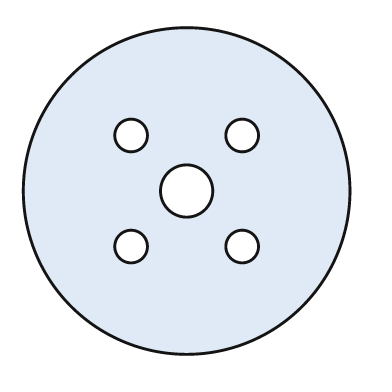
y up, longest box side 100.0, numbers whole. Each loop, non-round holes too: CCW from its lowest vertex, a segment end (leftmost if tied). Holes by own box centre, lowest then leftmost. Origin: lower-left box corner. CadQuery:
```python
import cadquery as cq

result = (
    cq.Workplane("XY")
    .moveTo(50.0, 50.0)
    .circle(50.0)
    .moveTo(33.0, 33.0)
    .circle(5.0)
    .moveTo(67.0, 33.0)
    .circle(5.0)
    .moveTo(50.0, 50.0)
    .circle(8.0)
    .moveTo(33.0, 67.0)
    .circle(5.0)
    .moveTo(67.0, 67.0)
    .circle(5.0)
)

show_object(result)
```